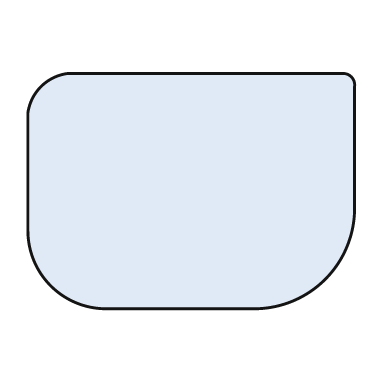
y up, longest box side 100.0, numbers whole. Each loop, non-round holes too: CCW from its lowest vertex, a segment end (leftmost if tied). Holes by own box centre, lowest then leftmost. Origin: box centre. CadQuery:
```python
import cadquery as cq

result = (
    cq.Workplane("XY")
    .moveTo(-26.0, -36.0)
    .lineTo(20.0, -36.0)
    .threePointArc((41.0, -27.0), (50.0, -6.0))
    .lineTo(50.0, 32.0)
    .threePointArc((49.0, 35.0), (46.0, 36.0))
    .lineTo(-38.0, 36.0)
    .threePointArc((-46.0, 32.0), (-50.0, 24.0))
    .lineTo(-50.0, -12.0)
    .threePointArc((-43.0, -29.0), (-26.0, -36.0))
    .close()
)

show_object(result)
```